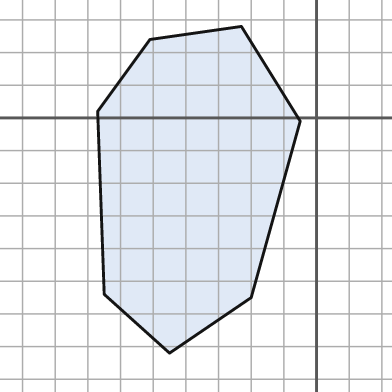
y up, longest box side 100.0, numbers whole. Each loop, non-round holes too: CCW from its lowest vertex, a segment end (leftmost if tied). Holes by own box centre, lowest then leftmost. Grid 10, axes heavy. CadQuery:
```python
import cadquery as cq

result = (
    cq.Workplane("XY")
    .moveTo(-45.0, -72.0)
    .lineTo(-20.0, -55.0)
    .lineTo(-5.0, -1.0)
    .lineTo(-23.0, 28.0)
    .lineTo(-51.0, 24.0)
    .lineTo(-67.0, 2.0)
    .lineTo(-65.0, -54.0)
    .close()
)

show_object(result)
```